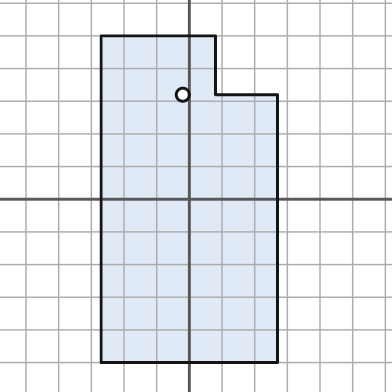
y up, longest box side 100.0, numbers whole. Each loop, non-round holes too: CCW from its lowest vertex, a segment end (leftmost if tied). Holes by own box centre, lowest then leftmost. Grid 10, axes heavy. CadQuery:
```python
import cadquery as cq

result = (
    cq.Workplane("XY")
    .moveTo(-27.0, -50.0)
    .lineTo(27.0, -50.0)
    .lineTo(27.0, 32.0)
    .lineTo(8.0, 32.0)
    .lineTo(8.0, 50.0)
    .lineTo(-27.0, 50.0)
    .close()
    .moveTo(-2.0, 32.0)
    .circle(2.0)
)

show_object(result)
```